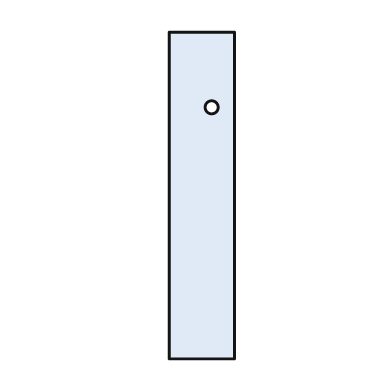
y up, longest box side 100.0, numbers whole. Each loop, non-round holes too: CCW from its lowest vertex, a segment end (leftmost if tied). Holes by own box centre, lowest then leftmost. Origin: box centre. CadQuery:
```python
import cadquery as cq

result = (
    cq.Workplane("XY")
    .moveTo(-10.0, -50.0)
    .lineTo(10.0, -50.0)
    .lineTo(10.0, 50.0)
    .lineTo(-10.0, 50.0)
    .close()
    .moveTo(3.0, 27.0)
    .circle(2.0)
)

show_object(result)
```